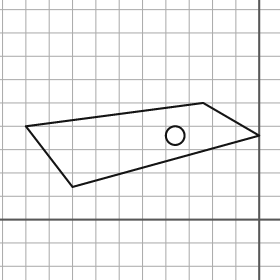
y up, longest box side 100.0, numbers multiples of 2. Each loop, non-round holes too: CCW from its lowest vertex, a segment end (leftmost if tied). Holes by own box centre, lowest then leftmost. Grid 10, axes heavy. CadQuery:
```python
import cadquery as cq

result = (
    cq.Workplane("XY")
    .moveTo(-80.0, 14.0)
    .lineTo(0.0, 36.0)
    .lineTo(-24.0, 50.0)
    .lineTo(-100.0, 40.0)
    .close()
    .moveTo(-36.0, 36.0)
    .circle(4.0)
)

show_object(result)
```